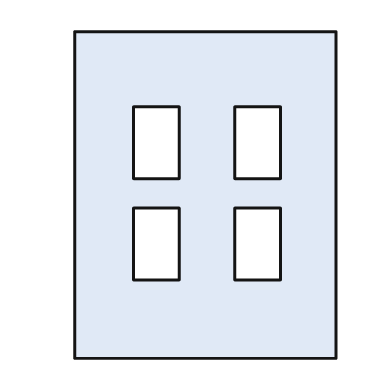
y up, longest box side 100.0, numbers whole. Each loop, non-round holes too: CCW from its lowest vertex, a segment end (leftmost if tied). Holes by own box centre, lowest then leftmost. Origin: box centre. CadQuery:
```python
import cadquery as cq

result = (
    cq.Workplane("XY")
    .moveTo(-40.0, -50.0)
    .lineTo(40.0, -50.0)
    .lineTo(40.0, 50.0)
    .lineTo(-40.0, 50.0)
    .close()
    .moveTo(-22.0, -26.0)
    .lineTo(-8.0, -26.0)
    .lineTo(-8.0, -4.0)
    .lineTo(-22.0, -4.0)
    .close()
    .moveTo(9.0, -26.0)
    .lineTo(23.0, -26.0)
    .lineTo(23.0, -4.0)
    .lineTo(9.0, -4.0)
    .close()
    .moveTo(-22.0, 5.0)
    .lineTo(-8.0, 5.0)
    .lineTo(-8.0, 27.0)
    .lineTo(-22.0, 27.0)
    .close()
    .moveTo(9.0, 5.0)
    .lineTo(23.0, 5.0)
    .lineTo(23.0, 27.0)
    .lineTo(9.0, 27.0)
    .close()
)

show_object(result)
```